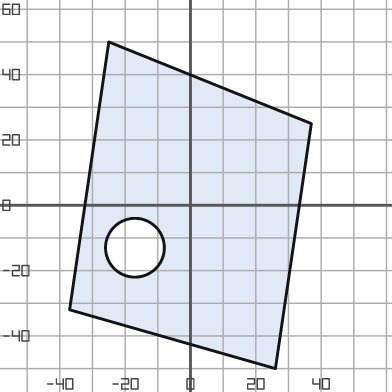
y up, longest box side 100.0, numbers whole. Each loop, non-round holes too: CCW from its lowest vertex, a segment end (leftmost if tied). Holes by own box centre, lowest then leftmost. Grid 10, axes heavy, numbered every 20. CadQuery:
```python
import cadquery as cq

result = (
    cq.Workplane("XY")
    .moveTo(26.0, -50.0)
    .lineTo(37.0, 25.0)
    .lineTo(-25.0, 50.0)
    .lineTo(-37.0, -32.0)
    .close()
    .moveTo(-17.0, -13.0)
    .circle(9.0)
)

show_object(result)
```